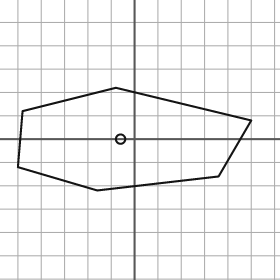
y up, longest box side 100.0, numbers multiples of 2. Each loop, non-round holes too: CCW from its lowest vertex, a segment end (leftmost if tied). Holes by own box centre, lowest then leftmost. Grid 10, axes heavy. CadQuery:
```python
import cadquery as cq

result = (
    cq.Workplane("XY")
    .moveTo(-16.0, -22.0)
    .lineTo(36.0, -16.0)
    .lineTo(50.0, 8.0)
    .lineTo(-8.0, 22.0)
    .lineTo(-48.0, 12.0)
    .lineTo(-50.0, -12.0)
    .close()
    .moveTo(-6.0, 0.0)
    .circle(2.0)
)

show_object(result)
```